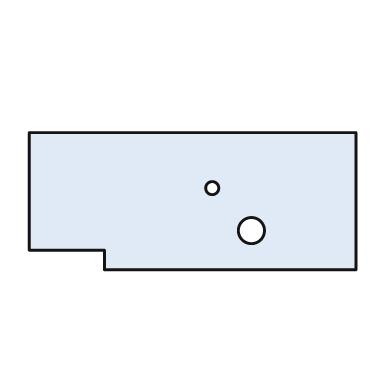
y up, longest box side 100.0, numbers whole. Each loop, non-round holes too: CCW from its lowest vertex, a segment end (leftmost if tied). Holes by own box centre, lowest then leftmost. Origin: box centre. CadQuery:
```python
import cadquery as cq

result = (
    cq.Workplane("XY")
    .moveTo(-27.0, -21.0)
    .lineTo(50.0, -21.0)
    .lineTo(50.0, 21.0)
    .lineTo(-50.0, 21.0)
    .lineTo(-50.0, -15.0)
    .lineTo(-27.0, -15.0)
    .close()
    .moveTo(18.0, -9.0)
    .circle(4.0)
    .moveTo(6.0, 4.0)
    .circle(2.0)
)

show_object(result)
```